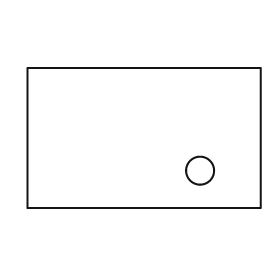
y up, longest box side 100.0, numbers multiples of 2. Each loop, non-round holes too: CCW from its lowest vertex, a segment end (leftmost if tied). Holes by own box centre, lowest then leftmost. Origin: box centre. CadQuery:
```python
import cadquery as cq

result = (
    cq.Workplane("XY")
    .moveTo(-50.0, -30.0)
    .lineTo(50.0, -30.0)
    .lineTo(50.0, 30.0)
    .lineTo(-50.0, 30.0)
    .close()
    .moveTo(24.0, -14.0)
    .circle(6.0)
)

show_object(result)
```